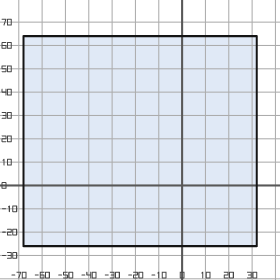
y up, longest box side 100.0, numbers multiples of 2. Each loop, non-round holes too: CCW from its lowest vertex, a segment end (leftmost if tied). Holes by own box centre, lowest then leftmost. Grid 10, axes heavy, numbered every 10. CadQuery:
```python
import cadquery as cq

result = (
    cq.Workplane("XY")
    .moveTo(-68.0, -26.0)
    .lineTo(32.0, -26.0)
    .lineTo(32.0, 64.0)
    .lineTo(-68.0, 64.0)
    .close()
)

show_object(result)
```